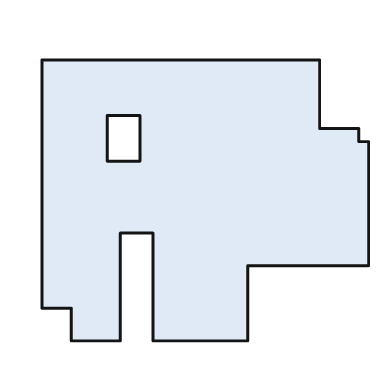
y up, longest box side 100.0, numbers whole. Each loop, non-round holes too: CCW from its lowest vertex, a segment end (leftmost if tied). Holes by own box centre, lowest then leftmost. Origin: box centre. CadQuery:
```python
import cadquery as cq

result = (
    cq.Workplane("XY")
    .moveTo(-41.0, -43.0)
    .lineTo(-26.0, -43.0)
    .lineTo(-26.0, -10.0)
    .lineTo(-16.0, -10.0)
    .lineTo(-16.0, -43.0)
    .lineTo(13.0, -43.0)
    .lineTo(13.0, -20.0)
    .lineTo(50.0, -20.0)
    .lineTo(50.0, 18.0)
    .lineTo(47.0, 18.0)
    .lineTo(47.0, 22.0)
    .lineTo(35.0, 22.0)
    .lineTo(35.0, 43.0)
    .lineTo(-50.0, 43.0)
    .lineTo(-50.0, -33.0)
    .lineTo(-41.0, -33.0)
    .close()
    .moveTo(-30.0, 12.0)
    .lineTo(-20.0, 12.0)
    .lineTo(-20.0, 26.0)
    .lineTo(-30.0, 26.0)
    .close()
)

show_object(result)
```